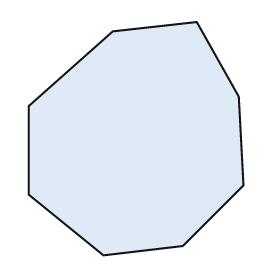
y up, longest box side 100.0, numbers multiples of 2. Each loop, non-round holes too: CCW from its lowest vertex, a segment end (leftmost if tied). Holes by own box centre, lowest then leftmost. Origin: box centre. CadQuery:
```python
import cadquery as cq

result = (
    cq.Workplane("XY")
    .moveTo(-14.0, -50.0)
    .lineTo(20.0, -46.0)
    .lineTo(46.0, -20.0)
    .lineTo(44.0, 18.0)
    .lineTo(26.0, 50.0)
    .lineTo(-10.0, 46.0)
    .lineTo(-46.0, 14.0)
    .lineTo(-46.0, -24.0)
    .close()
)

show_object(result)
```